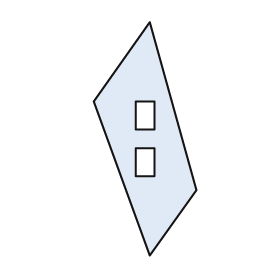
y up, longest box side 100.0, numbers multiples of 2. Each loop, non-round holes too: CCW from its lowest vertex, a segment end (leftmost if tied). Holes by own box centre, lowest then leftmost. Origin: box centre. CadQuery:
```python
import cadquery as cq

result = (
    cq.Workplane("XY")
    .moveTo(2.0, -50.0)
    .lineTo(22.0, -22.0)
    .lineTo(2.0, 50.0)
    .lineTo(-22.0, 16.0)
    .close()
    .moveTo(-4.0, -16.0)
    .lineTo(4.0, -16.0)
    .lineTo(4.0, -4.0)
    .lineTo(-4.0, -4.0)
    .close()
    .moveTo(-4.0, 4.0)
    .lineTo(4.0, 4.0)
    .lineTo(4.0, 16.0)
    .lineTo(-4.0, 16.0)
    .close()
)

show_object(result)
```